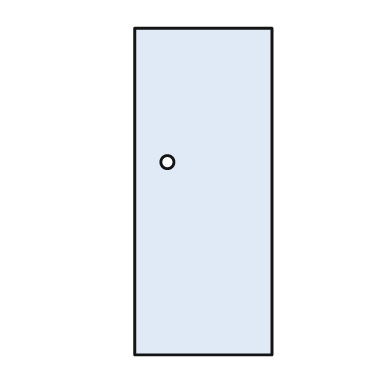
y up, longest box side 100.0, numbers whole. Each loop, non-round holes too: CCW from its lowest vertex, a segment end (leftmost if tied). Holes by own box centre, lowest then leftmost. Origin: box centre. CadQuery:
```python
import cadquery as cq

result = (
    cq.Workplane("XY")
    .moveTo(-21.0, -50.0)
    .lineTo(21.0, -50.0)
    .lineTo(21.0, 50.0)
    .lineTo(-21.0, 50.0)
    .close()
    .moveTo(-11.0, 9.0)
    .circle(2.0)
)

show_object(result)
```